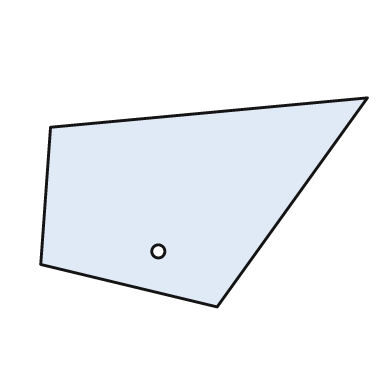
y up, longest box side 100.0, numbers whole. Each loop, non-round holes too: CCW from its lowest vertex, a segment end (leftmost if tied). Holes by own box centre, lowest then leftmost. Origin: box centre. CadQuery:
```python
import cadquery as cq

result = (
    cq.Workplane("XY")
    .moveTo(4.0, -32.0)
    .lineTo(50.0, 32.0)
    .lineTo(-47.0, 23.0)
    .lineTo(-50.0, -19.0)
    .close()
    .moveTo(-14.0, -15.0)
    .circle(2.0)
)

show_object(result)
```